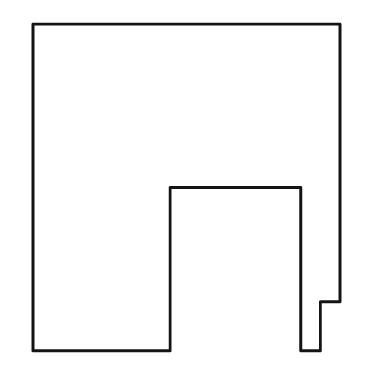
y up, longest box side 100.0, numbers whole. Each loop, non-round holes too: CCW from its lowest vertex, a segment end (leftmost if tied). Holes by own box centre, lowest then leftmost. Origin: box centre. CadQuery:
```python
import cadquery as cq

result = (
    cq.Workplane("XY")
    .moveTo(-47.0, -50.0)
    .lineTo(-5.0, -50.0)
    .lineTo(-5.0, 0.0)
    .lineTo(35.0, 0.0)
    .lineTo(35.0, -50.0)
    .lineTo(41.0, -50.0)
    .lineTo(41.0, -35.0)
    .lineTo(47.0, -35.0)
    .lineTo(47.0, 50.0)
    .lineTo(-47.0, 50.0)
    .close()
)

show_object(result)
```